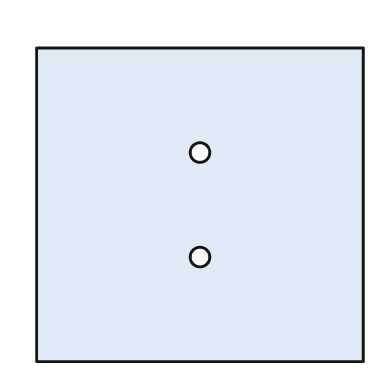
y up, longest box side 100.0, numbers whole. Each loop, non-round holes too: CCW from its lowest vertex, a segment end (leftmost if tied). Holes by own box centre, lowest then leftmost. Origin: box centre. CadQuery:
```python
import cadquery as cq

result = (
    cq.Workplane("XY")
    .moveTo(-50.0, -48.0)
    .lineTo(50.0, -48.0)
    .lineTo(50.0, 48.0)
    .lineTo(-50.0, 48.0)
    .close()
    .moveTo(0.0, -16.0)
    .circle(3.0)
    .moveTo(0.0, 16.0)
    .circle(3.0)
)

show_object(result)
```